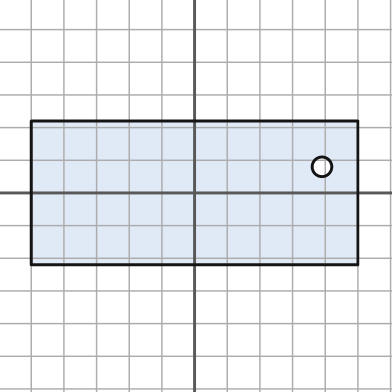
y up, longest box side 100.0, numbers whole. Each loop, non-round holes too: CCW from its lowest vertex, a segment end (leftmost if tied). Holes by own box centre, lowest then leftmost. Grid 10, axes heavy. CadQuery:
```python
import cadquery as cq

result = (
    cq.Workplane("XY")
    .moveTo(-50.0, -22.0)
    .lineTo(50.0, -22.0)
    .lineTo(50.0, 22.0)
    .lineTo(-50.0, 22.0)
    .close()
    .moveTo(39.0, 8.0)
    .circle(3.0)
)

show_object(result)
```